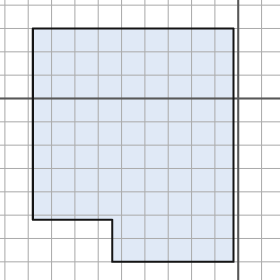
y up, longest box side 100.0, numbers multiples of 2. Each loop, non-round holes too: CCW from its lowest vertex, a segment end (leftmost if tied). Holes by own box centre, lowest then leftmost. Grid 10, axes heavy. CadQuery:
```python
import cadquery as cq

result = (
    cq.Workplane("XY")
    .moveTo(-54.0, -70.0)
    .lineTo(-2.0, -70.0)
    .lineTo(-2.0, 30.0)
    .lineTo(-88.0, 30.0)
    .lineTo(-88.0, -52.0)
    .lineTo(-54.0, -52.0)
    .close()
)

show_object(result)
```